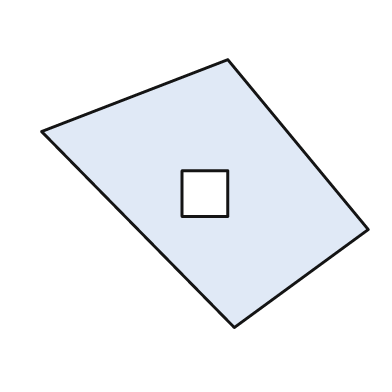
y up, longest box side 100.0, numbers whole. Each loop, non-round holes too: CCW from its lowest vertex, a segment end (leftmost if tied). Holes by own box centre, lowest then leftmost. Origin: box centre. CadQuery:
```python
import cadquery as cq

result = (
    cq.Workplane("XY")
    .moveTo(9.0, -41.0)
    .lineTo(50.0, -11.0)
    .lineTo(7.0, 41.0)
    .lineTo(-50.0, 19.0)
    .close()
    .moveTo(-7.0, -7.0)
    .lineTo(7.0, -7.0)
    .lineTo(7.0, 7.0)
    .lineTo(-7.0, 7.0)
    .close()
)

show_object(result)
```